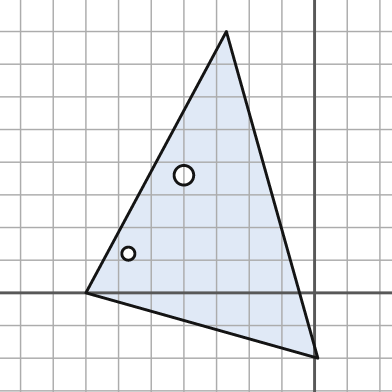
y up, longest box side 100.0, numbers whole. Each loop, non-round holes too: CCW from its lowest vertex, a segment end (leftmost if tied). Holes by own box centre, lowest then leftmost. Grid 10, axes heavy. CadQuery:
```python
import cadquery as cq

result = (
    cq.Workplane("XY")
    .moveTo(1.0, -20.0)
    .lineTo(-27.0, 80.0)
    .lineTo(-70.0, 0.0)
    .close()
    .moveTo(-57.0, 12.0)
    .circle(2.0)
    .moveTo(-40.0, 36.0)
    .circle(3.0)
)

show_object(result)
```